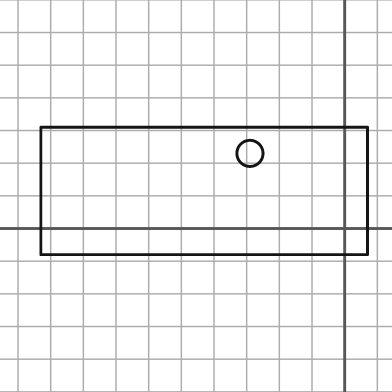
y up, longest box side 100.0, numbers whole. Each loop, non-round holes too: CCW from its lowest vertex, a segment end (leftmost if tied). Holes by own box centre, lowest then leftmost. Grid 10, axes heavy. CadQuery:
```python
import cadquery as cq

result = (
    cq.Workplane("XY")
    .moveTo(-93.0, -8.0)
    .lineTo(7.0, -8.0)
    .lineTo(7.0, 31.0)
    .lineTo(-93.0, 31.0)
    .close()
    .moveTo(-29.0, 23.0)
    .circle(4.0)
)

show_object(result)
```